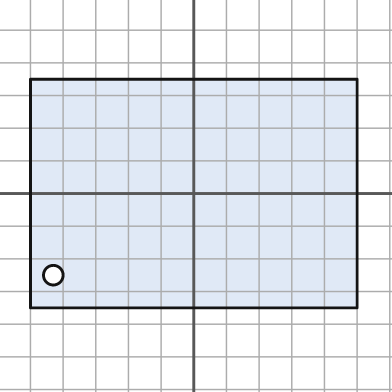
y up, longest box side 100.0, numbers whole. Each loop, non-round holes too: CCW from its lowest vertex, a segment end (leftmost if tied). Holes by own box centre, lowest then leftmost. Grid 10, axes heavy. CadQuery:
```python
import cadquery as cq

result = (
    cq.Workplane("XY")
    .moveTo(-50.0, -35.0)
    .lineTo(50.0, -35.0)
    .lineTo(50.0, 35.0)
    .lineTo(-50.0, 35.0)
    .close()
    .moveTo(-43.0, -25.0)
    .circle(3.0)
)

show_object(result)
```